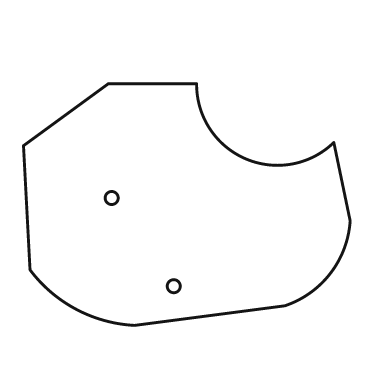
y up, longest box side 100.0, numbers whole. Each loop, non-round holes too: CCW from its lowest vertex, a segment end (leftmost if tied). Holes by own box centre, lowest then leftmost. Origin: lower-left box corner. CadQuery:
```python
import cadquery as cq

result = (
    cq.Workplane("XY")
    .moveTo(34.0, 0.0)
    .lineTo(80.0, 6.0)
    .threePointArc((94.0, 16.0), (100.0, 32.0))
    .lineTo(95.0, 56.0)
    .threePointArc((68.0, 51.0), (53.0, 74.0))
    .lineTo(26.0, 74.0)
    .lineTo(0.0, 55.0)
    .lineTo(2.0, 17.0)
    .threePointArc((16.0, 5.0), (34.0, 0.0))
    .close()
    .moveTo(46.0, 12.0)
    .circle(2.0)
    .moveTo(27.0, 39.0)
    .circle(2.0)
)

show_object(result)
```